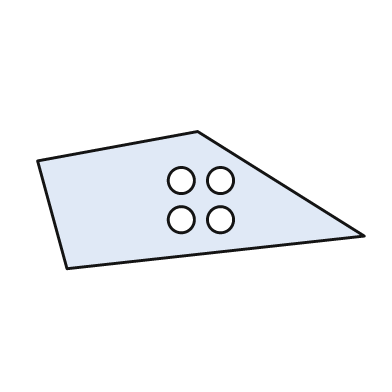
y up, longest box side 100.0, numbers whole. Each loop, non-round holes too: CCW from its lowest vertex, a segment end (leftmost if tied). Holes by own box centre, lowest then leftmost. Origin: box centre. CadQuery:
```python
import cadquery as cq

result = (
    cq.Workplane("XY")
    .moveTo(-41.0, -21.0)
    .lineTo(50.0, -11.0)
    .lineTo(-1.0, 21.0)
    .lineTo(-50.0, 12.0)
    .close()
    .moveTo(-6.0, -6.0)
    .circle(4.0)
    .moveTo(6.0, -6.0)
    .circle(4.0)
    .moveTo(-6.0, 6.0)
    .circle(4.0)
    .moveTo(6.0, 6.0)
    .circle(4.0)
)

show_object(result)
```